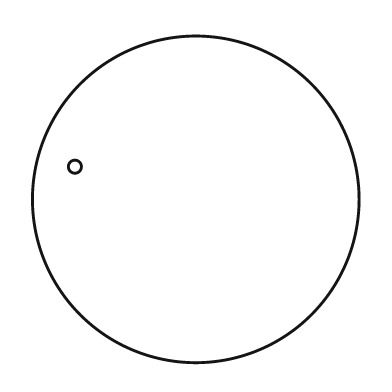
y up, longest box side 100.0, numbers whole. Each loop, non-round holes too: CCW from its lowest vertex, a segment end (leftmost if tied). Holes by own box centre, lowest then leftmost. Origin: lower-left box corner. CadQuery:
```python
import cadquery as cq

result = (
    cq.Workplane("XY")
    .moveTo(50.0, 50.0)
    .circle(50.0)
    .moveTo(13.0, 60.0)
    .circle(2.0)
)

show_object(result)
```